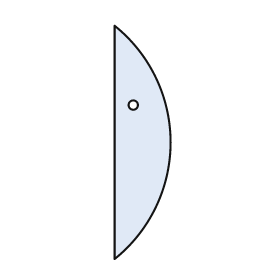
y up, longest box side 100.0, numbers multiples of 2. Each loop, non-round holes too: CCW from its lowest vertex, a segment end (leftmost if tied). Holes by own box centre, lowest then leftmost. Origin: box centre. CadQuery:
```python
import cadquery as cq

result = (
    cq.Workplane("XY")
    .moveTo(-12.0, -50.0)
    .threePointArc((12.0, 0.0), (-12.0, 50.0))
    .close()
    .moveTo(-4.0, 16.0)
    .circle(2.0)
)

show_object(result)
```